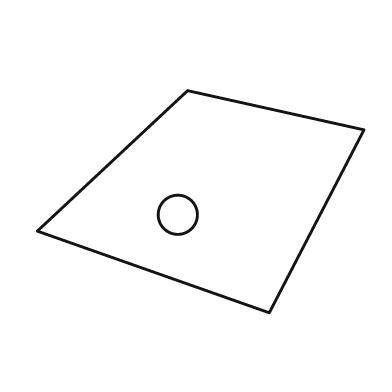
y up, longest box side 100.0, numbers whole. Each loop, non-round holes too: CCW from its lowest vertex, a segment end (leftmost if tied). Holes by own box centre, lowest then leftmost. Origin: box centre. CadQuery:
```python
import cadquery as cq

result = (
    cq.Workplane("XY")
    .moveTo(21.0, -34.0)
    .lineTo(50.0, 22.0)
    .lineTo(-4.0, 34.0)
    .lineTo(-50.0, -9.0)
    .close()
    .moveTo(-7.0, -4.0)
    .circle(6.0)
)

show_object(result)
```